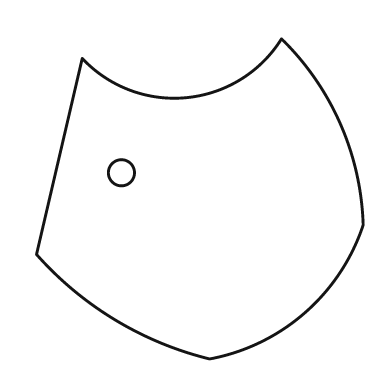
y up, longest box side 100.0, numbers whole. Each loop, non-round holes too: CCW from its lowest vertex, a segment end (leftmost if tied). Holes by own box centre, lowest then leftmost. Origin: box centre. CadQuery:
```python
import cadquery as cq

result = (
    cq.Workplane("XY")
    .moveTo(3.0, -49.0)
    .threePointArc((32.0, -35.0), (50.0, -8.0))
    .threePointArc((43.0, 23.0), (25.0, 49.0))
    .threePointArc((-4.0, 31.0), (-36.0, 43.0))
    .lineTo(-50.0, -17.0)
    .threePointArc((-26.0, -37.0), (3.0, -49.0))
    .close()
    .moveTo(-24.0, 8.0)
    .circle(4.0)
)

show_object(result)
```